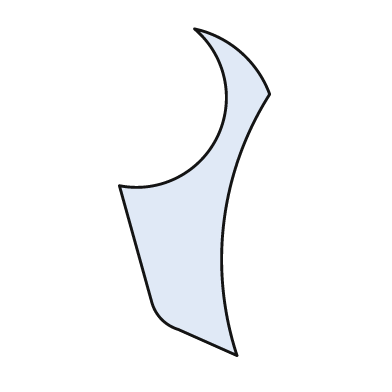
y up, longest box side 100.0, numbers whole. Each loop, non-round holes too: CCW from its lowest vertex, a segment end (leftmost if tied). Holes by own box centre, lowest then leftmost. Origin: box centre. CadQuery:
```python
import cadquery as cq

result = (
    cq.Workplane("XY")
    .moveTo(13.0, -50.0)
    .threePointArc((9.0, -9.0), (23.0, 30.0))
    .threePointArc((14.0, 43.0), (0.0, 50.0))
    .threePointArc((7.0, 17.0), (-23.0, 2.0))
    .lineTo(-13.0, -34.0)
    .threePointArc((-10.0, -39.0), (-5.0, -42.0))
    .close()
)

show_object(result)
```